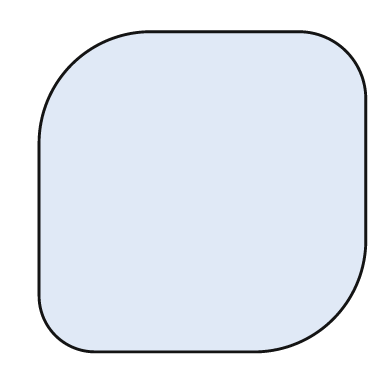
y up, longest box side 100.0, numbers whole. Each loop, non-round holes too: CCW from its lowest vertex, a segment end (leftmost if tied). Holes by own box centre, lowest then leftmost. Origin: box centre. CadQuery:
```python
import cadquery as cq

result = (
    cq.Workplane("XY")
    .moveTo(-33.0, -49.0)
    .lineTo(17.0, -49.0)
    .threePointArc((40.0, -39.0), (50.0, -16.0))
    .lineTo(50.0, 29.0)
    .threePointArc((44.0, 43.0), (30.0, 49.0))
    .lineTo(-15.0, 49.0)
    .threePointArc((-40.0, 39.0), (-50.0, 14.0))
    .lineTo(-50.0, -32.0)
    .threePointArc((-45.0, -44.0), (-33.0, -49.0))
    .close()
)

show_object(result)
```